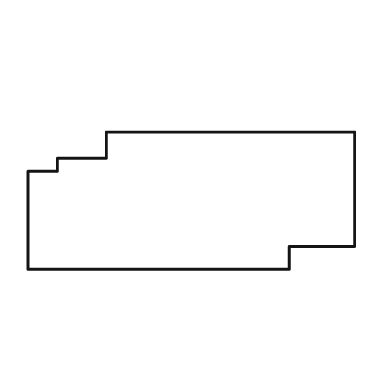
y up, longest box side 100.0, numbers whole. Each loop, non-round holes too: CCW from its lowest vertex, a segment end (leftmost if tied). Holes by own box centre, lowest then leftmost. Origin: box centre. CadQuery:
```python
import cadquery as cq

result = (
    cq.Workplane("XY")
    .moveTo(-50.0, -21.0)
    .lineTo(30.0, -21.0)
    .lineTo(30.0, -14.0)
    .lineTo(50.0, -14.0)
    .lineTo(50.0, 21.0)
    .lineTo(-26.0, 21.0)
    .lineTo(-26.0, 13.0)
    .lineTo(-41.0, 13.0)
    .lineTo(-41.0, 9.0)
    .lineTo(-50.0, 9.0)
    .close()
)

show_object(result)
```